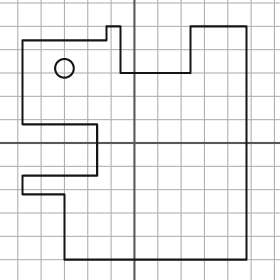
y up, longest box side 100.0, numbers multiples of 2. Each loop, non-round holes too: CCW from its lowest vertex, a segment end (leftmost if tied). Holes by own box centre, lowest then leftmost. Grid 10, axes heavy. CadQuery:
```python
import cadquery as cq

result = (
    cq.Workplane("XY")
    .moveTo(-30.0, -50.0)
    .lineTo(48.0, -50.0)
    .lineTo(48.0, 50.0)
    .lineTo(24.0, 50.0)
    .lineTo(24.0, 30.0)
    .lineTo(-6.0, 30.0)
    .lineTo(-6.0, 50.0)
    .lineTo(-12.0, 50.0)
    .lineTo(-12.0, 44.0)
    .lineTo(-48.0, 44.0)
    .lineTo(-48.0, 8.0)
    .lineTo(-16.0, 8.0)
    .lineTo(-16.0, -14.0)
    .lineTo(-48.0, -14.0)
    .lineTo(-48.0, -22.0)
    .lineTo(-30.0, -22.0)
    .close()
    .moveTo(-30.0, 32.0)
    .circle(4.0)
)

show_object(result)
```